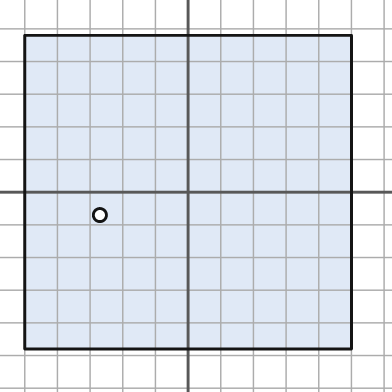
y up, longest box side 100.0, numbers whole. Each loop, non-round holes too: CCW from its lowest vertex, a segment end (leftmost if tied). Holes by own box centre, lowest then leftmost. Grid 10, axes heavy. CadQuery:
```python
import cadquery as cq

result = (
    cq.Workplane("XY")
    .moveTo(-50.0, -48.0)
    .lineTo(50.0, -48.0)
    .lineTo(50.0, 48.0)
    .lineTo(-50.0, 48.0)
    .close()
    .moveTo(-27.0, -7.0)
    .circle(2.0)
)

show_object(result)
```